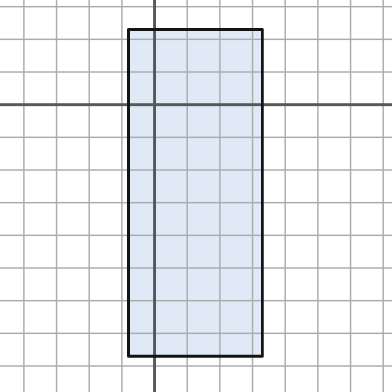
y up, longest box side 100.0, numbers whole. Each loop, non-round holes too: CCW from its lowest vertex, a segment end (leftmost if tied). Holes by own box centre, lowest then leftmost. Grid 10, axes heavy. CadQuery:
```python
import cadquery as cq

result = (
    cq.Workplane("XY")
    .moveTo(-8.0, -77.0)
    .lineTo(33.0, -77.0)
    .lineTo(33.0, 23.0)
    .lineTo(-8.0, 23.0)
    .close()
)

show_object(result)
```